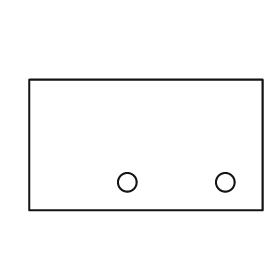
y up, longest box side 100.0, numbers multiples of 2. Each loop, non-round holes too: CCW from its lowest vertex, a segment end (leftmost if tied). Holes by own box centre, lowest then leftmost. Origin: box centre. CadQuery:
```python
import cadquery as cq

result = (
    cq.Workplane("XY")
    .moveTo(-50.0, -28.0)
    .lineTo(50.0, -28.0)
    .lineTo(50.0, 28.0)
    .lineTo(-50.0, 28.0)
    .close()
    .moveTo(-8.0, -16.0)
    .circle(4.0)
    .moveTo(34.0, -16.0)
    .circle(4.0)
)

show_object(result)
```